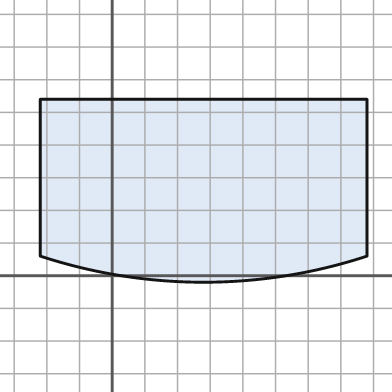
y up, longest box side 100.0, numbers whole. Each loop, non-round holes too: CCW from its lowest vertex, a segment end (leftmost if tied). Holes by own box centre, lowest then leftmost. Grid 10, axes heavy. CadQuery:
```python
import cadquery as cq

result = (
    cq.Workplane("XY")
    .moveTo(-22.0, 6.0)
    .threePointArc((28.0, -2.0), (78.0, 6.0))
    .lineTo(78.0, 54.0)
    .lineTo(-22.0, 54.0)
    .close()
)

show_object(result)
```